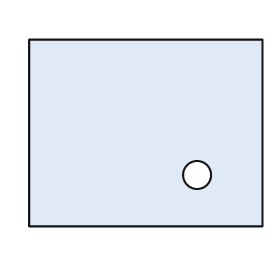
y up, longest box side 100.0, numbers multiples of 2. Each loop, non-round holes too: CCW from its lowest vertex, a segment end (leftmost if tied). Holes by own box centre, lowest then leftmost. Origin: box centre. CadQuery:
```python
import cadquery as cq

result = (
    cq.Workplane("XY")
    .moveTo(-50.0, -40.0)
    .lineTo(50.0, -40.0)
    .lineTo(50.0, 40.0)
    .lineTo(-50.0, 40.0)
    .close()
    .moveTo(22.0, -18.0)
    .circle(6.0)
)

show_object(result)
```